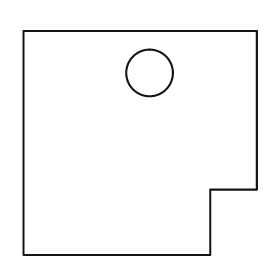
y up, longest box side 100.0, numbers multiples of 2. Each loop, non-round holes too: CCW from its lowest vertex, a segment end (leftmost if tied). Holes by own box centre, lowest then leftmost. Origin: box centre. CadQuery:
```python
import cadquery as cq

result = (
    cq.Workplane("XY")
    .moveTo(-50.0, -48.0)
    .lineTo(30.0, -48.0)
    .lineTo(30.0, -20.0)
    .lineTo(50.0, -20.0)
    .lineTo(50.0, 48.0)
    .lineTo(-50.0, 48.0)
    .close()
    .moveTo(4.0, 30.0)
    .circle(10.0)
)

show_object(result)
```